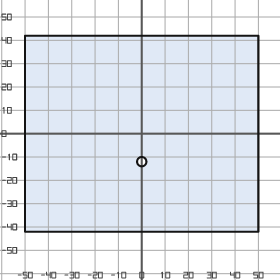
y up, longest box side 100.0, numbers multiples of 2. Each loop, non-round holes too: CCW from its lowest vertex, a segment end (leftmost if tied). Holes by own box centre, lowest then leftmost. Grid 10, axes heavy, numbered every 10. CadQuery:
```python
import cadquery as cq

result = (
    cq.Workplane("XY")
    .moveTo(-50.0, -42.0)
    .lineTo(50.0, -42.0)
    .lineTo(50.0, 42.0)
    .lineTo(-50.0, 42.0)
    .close()
    .moveTo(0.0, -12.0)
    .circle(2.0)
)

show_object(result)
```